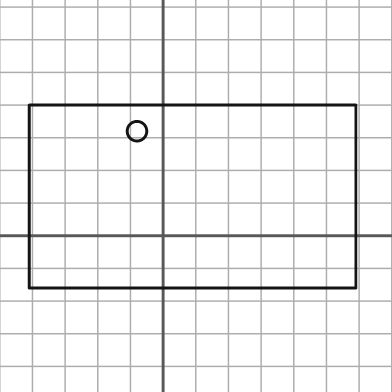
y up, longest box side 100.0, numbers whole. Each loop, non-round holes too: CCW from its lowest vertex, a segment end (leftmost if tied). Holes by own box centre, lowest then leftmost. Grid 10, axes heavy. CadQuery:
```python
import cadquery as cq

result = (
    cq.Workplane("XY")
    .moveTo(-41.0, -16.0)
    .lineTo(59.0, -16.0)
    .lineTo(59.0, 40.0)
    .lineTo(-41.0, 40.0)
    .close()
    .moveTo(-8.0, 32.0)
    .circle(3.0)
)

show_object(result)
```